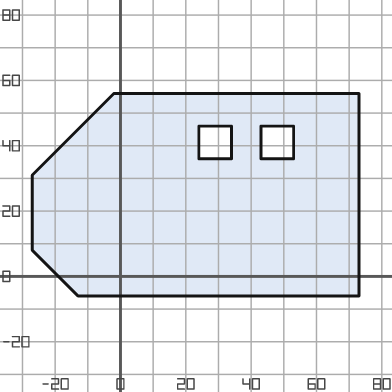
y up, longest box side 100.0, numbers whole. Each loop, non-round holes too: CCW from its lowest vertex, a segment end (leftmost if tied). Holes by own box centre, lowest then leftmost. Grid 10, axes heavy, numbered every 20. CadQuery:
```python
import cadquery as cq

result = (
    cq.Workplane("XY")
    .moveTo(-13.0, -6.0)
    .lineTo(73.0, -6.0)
    .lineTo(73.0, 56.0)
    .lineTo(-2.0, 56.0)
    .lineTo(-27.0, 31.0)
    .lineTo(-27.0, 8.0)
    .close()
    .moveTo(24.0, 36.0)
    .lineTo(34.0, 36.0)
    .lineTo(34.0, 46.0)
    .lineTo(24.0, 46.0)
    .close()
    .moveTo(43.0, 36.0)
    .lineTo(53.0, 36.0)
    .lineTo(53.0, 46.0)
    .lineTo(43.0, 46.0)
    .close()
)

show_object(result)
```